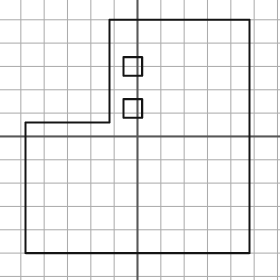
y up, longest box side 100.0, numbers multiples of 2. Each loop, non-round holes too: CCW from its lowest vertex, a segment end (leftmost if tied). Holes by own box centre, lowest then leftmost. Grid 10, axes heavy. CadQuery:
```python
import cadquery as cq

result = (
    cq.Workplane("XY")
    .moveTo(-48.0, -50.0)
    .lineTo(48.0, -50.0)
    .lineTo(48.0, 50.0)
    .lineTo(-12.0, 50.0)
    .lineTo(-12.0, 6.0)
    .lineTo(-48.0, 6.0)
    .close()
    .moveTo(-6.0, 8.0)
    .lineTo(2.0, 8.0)
    .lineTo(2.0, 16.0)
    .lineTo(-6.0, 16.0)
    .close()
    .moveTo(-6.0, 26.0)
    .lineTo(2.0, 26.0)
    .lineTo(2.0, 34.0)
    .lineTo(-6.0, 34.0)
    .close()
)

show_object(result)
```